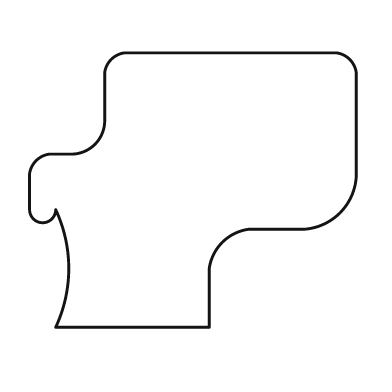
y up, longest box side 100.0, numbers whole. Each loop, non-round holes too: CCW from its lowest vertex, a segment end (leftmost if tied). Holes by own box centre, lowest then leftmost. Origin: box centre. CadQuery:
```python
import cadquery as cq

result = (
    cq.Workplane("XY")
    .moveTo(-42.0, -42.0)
    .lineTo(5.0, -42.0)
    .lineTo(5.0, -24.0)
    .threePointArc((9.0, -16.0), (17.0, -12.0))
    .lineTo(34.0, -12.0)
    .threePointArc((45.0, -7.0), (50.0, 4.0))
    .lineTo(50.0, 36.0)
    .threePointArc((48.0, 40.0), (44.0, 42.0))
    .lineTo(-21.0, 42.0)
    .threePointArc((-25.0, 40.0), (-27.0, 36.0))
    .lineTo(-27.0, 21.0)
    .threePointArc((-30.0, 14.0), (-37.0, 11.0))
    .lineTo(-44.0, 11.0)
    .threePointArc((-48.0, 9.0), (-50.0, 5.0))
    .lineTo(-50.0, -6.0)
    .threePointArc((-46.0, -10.0), (-42.0, -6.0))
    .threePointArc((-38.0, -24.0), (-42.0, -42.0))
    .close()
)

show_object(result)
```